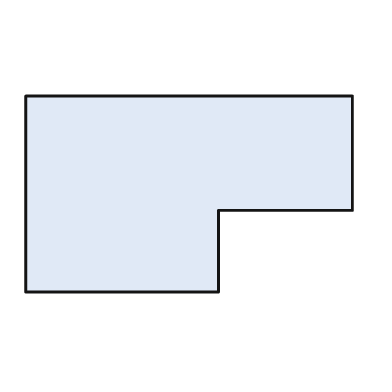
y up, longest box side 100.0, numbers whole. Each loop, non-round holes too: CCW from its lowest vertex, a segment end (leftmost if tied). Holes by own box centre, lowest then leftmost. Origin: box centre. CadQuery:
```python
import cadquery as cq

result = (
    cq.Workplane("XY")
    .moveTo(-50.0, -30.0)
    .lineTo(9.0, -30.0)
    .lineTo(9.0, -5.0)
    .lineTo(50.0, -5.0)
    .lineTo(50.0, 30.0)
    .lineTo(-50.0, 30.0)
    .close()
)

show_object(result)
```